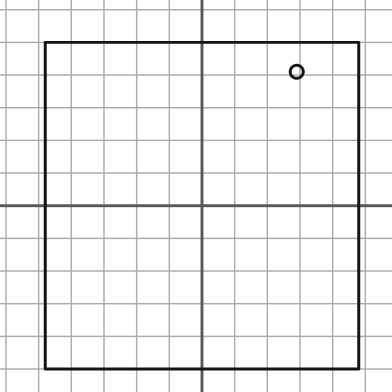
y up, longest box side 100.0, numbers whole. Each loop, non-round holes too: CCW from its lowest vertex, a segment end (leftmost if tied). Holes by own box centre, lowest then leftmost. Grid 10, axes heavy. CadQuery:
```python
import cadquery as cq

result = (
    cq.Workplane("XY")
    .moveTo(-48.0, -50.0)
    .lineTo(48.0, -50.0)
    .lineTo(48.0, 50.0)
    .lineTo(-48.0, 50.0)
    .close()
    .moveTo(29.0, 41.0)
    .circle(2.0)
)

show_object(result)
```